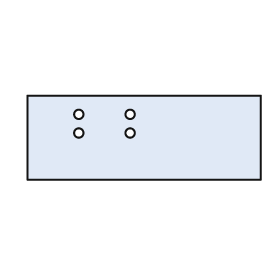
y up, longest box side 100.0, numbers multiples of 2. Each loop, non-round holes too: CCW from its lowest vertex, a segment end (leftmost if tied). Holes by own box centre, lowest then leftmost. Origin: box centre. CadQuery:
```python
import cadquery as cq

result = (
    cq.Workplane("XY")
    .moveTo(-50.0, -18.0)
    .lineTo(50.0, -18.0)
    .lineTo(50.0, 18.0)
    .lineTo(-50.0, 18.0)
    .close()
    .moveTo(-28.0, 2.0)
    .circle(2.0)
    .moveTo(-6.0, 2.0)
    .circle(2.0)
    .moveTo(-28.0, 10.0)
    .circle(2.0)
    .moveTo(-6.0, 10.0)
    .circle(2.0)
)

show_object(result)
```